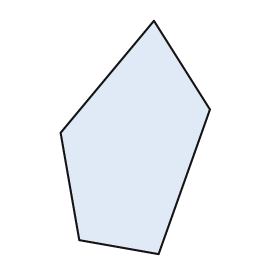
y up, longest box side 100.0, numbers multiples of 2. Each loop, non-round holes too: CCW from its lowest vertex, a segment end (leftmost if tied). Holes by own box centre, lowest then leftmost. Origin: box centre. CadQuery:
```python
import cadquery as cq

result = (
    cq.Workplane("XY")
    .moveTo(10.0, -50.0)
    .lineTo(32.0, 12.0)
    .lineTo(8.0, 50.0)
    .lineTo(-32.0, 2.0)
    .lineTo(-24.0, -44.0)
    .close()
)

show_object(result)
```